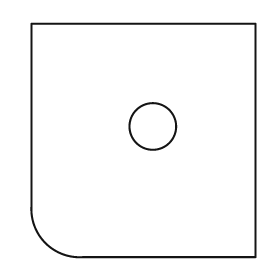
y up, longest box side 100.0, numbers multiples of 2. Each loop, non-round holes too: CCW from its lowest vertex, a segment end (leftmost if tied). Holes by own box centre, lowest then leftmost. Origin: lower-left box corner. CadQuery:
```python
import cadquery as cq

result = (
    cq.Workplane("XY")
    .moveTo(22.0, 0.0)
    .lineTo(96.0, 0.0)
    .lineTo(96.0, 100.0)
    .lineTo(0.0, 100.0)
    .lineTo(0.0, 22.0)
    .threePointArc((6.0, 6.0), (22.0, 0.0))
    .close()
    .moveTo(52.0, 56.0)
    .circle(10.0)
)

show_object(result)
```